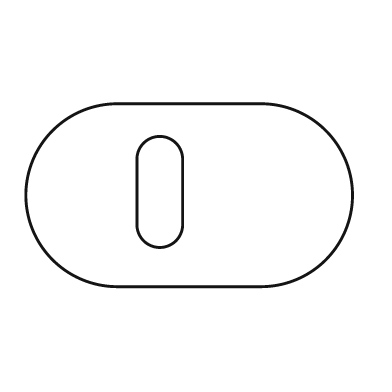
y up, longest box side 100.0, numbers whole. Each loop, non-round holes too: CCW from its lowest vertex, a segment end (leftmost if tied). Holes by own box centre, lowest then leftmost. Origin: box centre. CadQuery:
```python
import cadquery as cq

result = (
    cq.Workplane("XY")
    .moveTo(-22.0, -28.0)
    .lineTo(22.0, -28.0)
    .threePointArc((50.0, 0.0), (22.0, 28.0))
    .lineTo(-22.0, 28.0)
    .threePointArc((-50.0, 0.0), (-22.0, -28.0))
    .close()
    .moveTo(-16.0, -9.0)
    .threePointArc((-9.0, -16.0), (-2.0, -9.0))
    .lineTo(-2.0, 11.0)
    .threePointArc((-9.0, 18.0), (-16.0, 11.0))
    .close()
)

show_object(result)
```